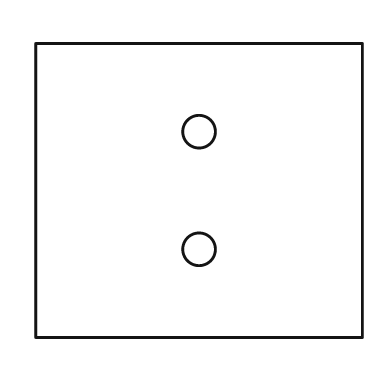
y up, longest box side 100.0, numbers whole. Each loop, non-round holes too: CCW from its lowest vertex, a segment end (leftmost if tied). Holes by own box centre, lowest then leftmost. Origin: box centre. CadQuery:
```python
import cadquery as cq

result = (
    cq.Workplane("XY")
    .moveTo(-50.0, -45.0)
    .lineTo(50.0, -45.0)
    .lineTo(50.0, 45.0)
    .lineTo(-50.0, 45.0)
    .close()
    .moveTo(0.0, -18.0)
    .circle(5.0)
    .moveTo(0.0, 18.0)
    .circle(5.0)
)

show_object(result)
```